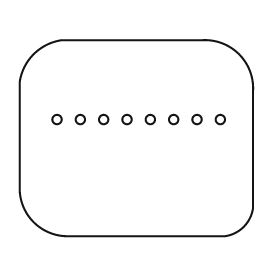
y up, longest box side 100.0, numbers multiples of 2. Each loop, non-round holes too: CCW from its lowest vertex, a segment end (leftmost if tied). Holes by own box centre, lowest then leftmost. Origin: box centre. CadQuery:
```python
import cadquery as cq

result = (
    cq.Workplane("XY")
    .moveTo(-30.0, -42.0)
    .lineTo(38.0, -42.0)
    .threePointArc((46.0, -38.0), (50.0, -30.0))
    .lineTo(50.0, 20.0)
    .threePointArc((44.0, 36.0), (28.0, 42.0))
    .lineTo(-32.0, 42.0)
    .threePointArc((-44.0, 36.0), (-50.0, 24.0))
    .lineTo(-50.0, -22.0)
    .threePointArc((-44.0, -36.0), (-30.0, -42.0))
    .close()
    .moveTo(-34.0, 8.0)
    .circle(2.0)
    .moveTo(-24.0, 8.0)
    .circle(2.0)
    .moveTo(-14.0, 8.0)
    .circle(2.0)
    .moveTo(-4.0, 8.0)
    .circle(2.0)
    .moveTo(6.0, 8.0)
    .circle(2.0)
    .moveTo(16.0, 8.0)
    .circle(2.0)
    .moveTo(26.0, 8.0)
    .circle(2.0)
    .moveTo(36.0, 8.0)
    .circle(2.0)
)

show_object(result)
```